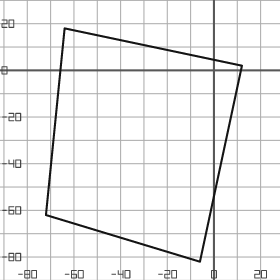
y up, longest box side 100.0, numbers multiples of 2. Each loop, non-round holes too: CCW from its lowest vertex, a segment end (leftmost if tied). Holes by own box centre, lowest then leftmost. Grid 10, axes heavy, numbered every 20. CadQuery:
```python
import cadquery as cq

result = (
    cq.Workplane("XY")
    .moveTo(-6.0, -82.0)
    .lineTo(12.0, 2.0)
    .lineTo(-64.0, 18.0)
    .lineTo(-72.0, -62.0)
    .close()
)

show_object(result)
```